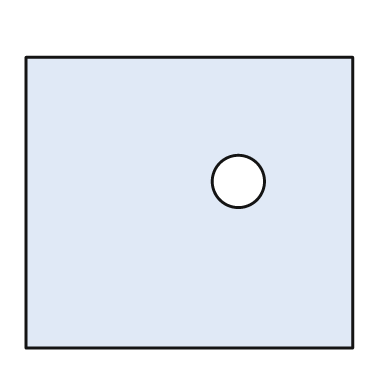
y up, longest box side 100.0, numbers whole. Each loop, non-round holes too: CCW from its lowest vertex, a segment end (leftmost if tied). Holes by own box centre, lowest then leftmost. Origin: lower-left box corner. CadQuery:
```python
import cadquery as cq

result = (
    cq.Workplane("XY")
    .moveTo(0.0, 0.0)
    .lineTo(100.0, 0.0)
    .lineTo(100.0, 89.0)
    .lineTo(0.0, 89.0)
    .close()
    .moveTo(65.0, 51.0)
    .circle(8.0)
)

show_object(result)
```